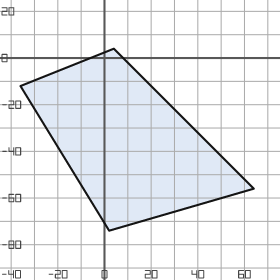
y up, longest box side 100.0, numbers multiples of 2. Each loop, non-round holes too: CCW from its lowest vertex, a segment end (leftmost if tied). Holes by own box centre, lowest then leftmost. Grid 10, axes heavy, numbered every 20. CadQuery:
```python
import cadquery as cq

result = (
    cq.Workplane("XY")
    .moveTo(2.0, -74.0)
    .lineTo(64.0, -56.0)
    .lineTo(4.0, 4.0)
    .lineTo(-36.0, -12.0)
    .close()
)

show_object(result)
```